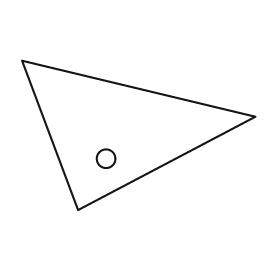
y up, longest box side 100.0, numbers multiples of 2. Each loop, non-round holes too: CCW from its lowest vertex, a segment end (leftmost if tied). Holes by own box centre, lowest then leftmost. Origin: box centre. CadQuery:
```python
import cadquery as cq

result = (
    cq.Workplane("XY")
    .moveTo(-26.0, -32.0)
    .lineTo(50.0, 8.0)
    .lineTo(-50.0, 32.0)
    .close()
    .moveTo(-14.0, -10.0)
    .circle(4.0)
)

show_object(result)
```